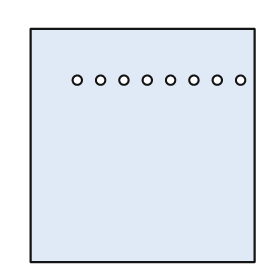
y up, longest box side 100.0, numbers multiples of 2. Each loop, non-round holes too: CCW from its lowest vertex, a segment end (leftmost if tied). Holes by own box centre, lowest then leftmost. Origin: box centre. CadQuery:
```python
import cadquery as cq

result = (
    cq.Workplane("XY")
    .moveTo(-48.0, -50.0)
    .lineTo(48.0, -50.0)
    .lineTo(48.0, 50.0)
    .lineTo(-48.0, 50.0)
    .close()
    .moveTo(-28.0, 28.0)
    .circle(2.0)
    .moveTo(-18.0, 28.0)
    .circle(2.0)
    .moveTo(-8.0, 28.0)
    .circle(2.0)
    .moveTo(2.0, 28.0)
    .circle(2.0)
    .moveTo(12.0, 28.0)
    .circle(2.0)
    .moveTo(22.0, 28.0)
    .circle(2.0)
    .moveTo(32.0, 28.0)
    .circle(2.0)
    .moveTo(42.0, 28.0)
    .circle(2.0)
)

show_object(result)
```